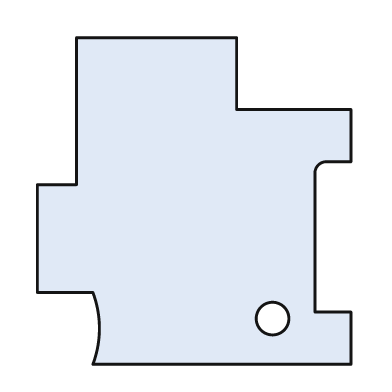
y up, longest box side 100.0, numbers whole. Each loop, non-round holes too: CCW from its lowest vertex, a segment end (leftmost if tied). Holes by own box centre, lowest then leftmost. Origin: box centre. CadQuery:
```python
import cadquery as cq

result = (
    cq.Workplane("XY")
    .moveTo(-31.0, -50.0)
    .lineTo(48.0, -50.0)
    .lineTo(48.0, -34.0)
    .lineTo(37.0, -34.0)
    .lineTo(37.0, 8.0)
    .threePointArc((38.0, 11.0), (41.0, 12.0))
    .lineTo(48.0, 12.0)
    .lineTo(48.0, 28.0)
    .lineTo(13.0, 28.0)
    .lineTo(13.0, 50.0)
    .lineTo(-36.0, 50.0)
    .lineTo(-36.0, 5.0)
    .lineTo(-48.0, 5.0)
    .lineTo(-48.0, -28.0)
    .lineTo(-31.0, -28.0)
    .threePointArc((-29.0, -39.0), (-31.0, -50.0))
    .close()
    .moveTo(24.0, -36.0)
    .circle(5.0)
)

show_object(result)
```